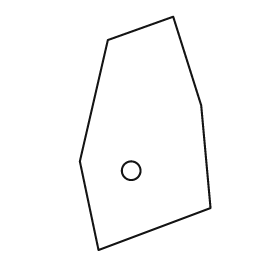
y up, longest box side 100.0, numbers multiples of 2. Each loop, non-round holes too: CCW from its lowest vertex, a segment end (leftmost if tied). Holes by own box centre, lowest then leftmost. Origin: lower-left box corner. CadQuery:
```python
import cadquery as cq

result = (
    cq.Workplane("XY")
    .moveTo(8.0, 0.0)
    .lineTo(56.0, 18.0)
    .lineTo(52.0, 62.0)
    .lineTo(40.0, 100.0)
    .lineTo(12.0, 90.0)
    .lineTo(0.0, 38.0)
    .close()
    .moveTo(22.0, 34.0)
    .circle(4.0)
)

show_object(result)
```